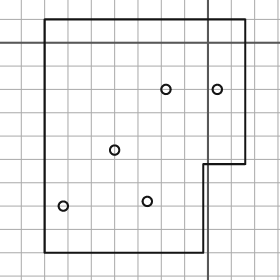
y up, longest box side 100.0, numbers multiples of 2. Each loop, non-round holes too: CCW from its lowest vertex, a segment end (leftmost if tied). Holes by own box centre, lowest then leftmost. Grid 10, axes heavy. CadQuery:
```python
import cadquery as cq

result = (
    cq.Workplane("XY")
    .moveTo(-70.0, -90.0)
    .lineTo(-2.0, -90.0)
    .lineTo(-2.0, -52.0)
    .lineTo(16.0, -52.0)
    .lineTo(16.0, 10.0)
    .lineTo(-70.0, 10.0)
    .close()
    .moveTo(-62.0, -70.0)
    .circle(2.0)
    .moveTo(-26.0, -68.0)
    .circle(2.0)
    .moveTo(-40.0, -46.0)
    .circle(2.0)
    .moveTo(-18.0, -20.0)
    .circle(2.0)
    .moveTo(4.0, -20.0)
    .circle(2.0)
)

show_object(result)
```